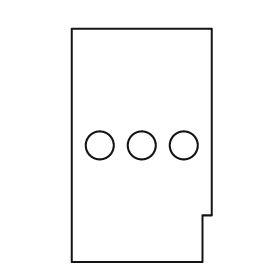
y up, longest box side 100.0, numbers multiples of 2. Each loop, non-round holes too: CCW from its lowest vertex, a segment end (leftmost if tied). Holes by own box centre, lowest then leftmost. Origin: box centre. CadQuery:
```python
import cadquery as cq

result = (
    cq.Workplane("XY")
    .moveTo(-30.0, -50.0)
    .lineTo(26.0, -50.0)
    .lineTo(26.0, -30.0)
    .lineTo(30.0, -30.0)
    .lineTo(30.0, 50.0)
    .lineTo(-30.0, 50.0)
    .close()
    .moveTo(-18.0, 0.0)
    .circle(6.0)
    .moveTo(0.0, 0.0)
    .circle(6.0)
    .moveTo(18.0, 0.0)
    .circle(6.0)
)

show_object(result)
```